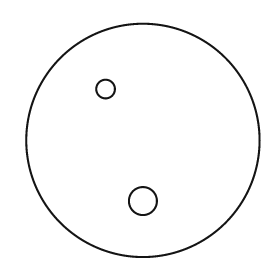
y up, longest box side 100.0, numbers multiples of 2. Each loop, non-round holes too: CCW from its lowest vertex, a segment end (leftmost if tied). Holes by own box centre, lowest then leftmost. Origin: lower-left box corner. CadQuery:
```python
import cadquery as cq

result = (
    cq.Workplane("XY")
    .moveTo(50.0, 50.0)
    .circle(50.0)
    .moveTo(50.0, 24.0)
    .circle(6.0)
    .moveTo(34.0, 72.0)
    .circle(4.0)
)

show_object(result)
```